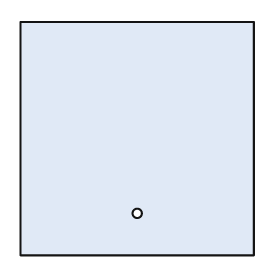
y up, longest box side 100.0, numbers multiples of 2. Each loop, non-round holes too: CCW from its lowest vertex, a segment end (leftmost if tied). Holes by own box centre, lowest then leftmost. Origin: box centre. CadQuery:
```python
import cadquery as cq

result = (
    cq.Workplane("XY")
    .moveTo(-50.0, -50.0)
    .lineTo(50.0, -50.0)
    .lineTo(50.0, 50.0)
    .lineTo(-50.0, 50.0)
    .close()
    .moveTo(0.0, -32.0)
    .circle(2.0)
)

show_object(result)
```